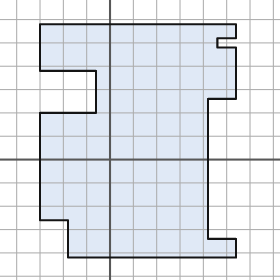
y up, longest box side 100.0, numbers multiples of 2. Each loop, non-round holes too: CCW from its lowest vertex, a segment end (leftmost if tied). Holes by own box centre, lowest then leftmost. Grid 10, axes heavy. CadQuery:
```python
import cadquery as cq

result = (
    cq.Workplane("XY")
    .moveTo(-18.0, -42.0)
    .lineTo(54.0, -42.0)
    .lineTo(54.0, -34.0)
    .lineTo(42.0, -34.0)
    .lineTo(42.0, 26.0)
    .lineTo(54.0, 26.0)
    .lineTo(54.0, 48.0)
    .lineTo(46.0, 48.0)
    .lineTo(46.0, 52.0)
    .lineTo(54.0, 52.0)
    .lineTo(54.0, 58.0)
    .lineTo(-30.0, 58.0)
    .lineTo(-30.0, 38.0)
    .lineTo(-6.0, 38.0)
    .lineTo(-6.0, 20.0)
    .lineTo(-30.0, 20.0)
    .lineTo(-30.0, -26.0)
    .lineTo(-18.0, -26.0)
    .close()
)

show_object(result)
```